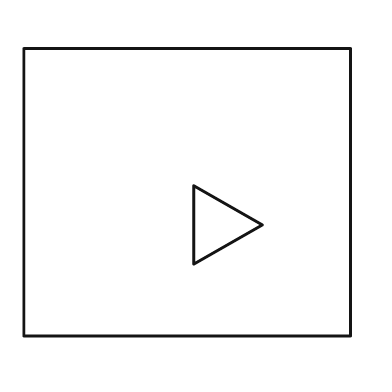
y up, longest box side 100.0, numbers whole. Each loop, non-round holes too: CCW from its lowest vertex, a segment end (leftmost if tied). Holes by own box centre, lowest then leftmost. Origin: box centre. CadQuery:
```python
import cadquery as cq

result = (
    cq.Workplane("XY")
    .moveTo(-50.0, -44.0)
    .lineTo(50.0, -44.0)
    .lineTo(50.0, 44.0)
    .lineTo(-50.0, 44.0)
    .close()
    .moveTo(2.0, -22.0)
    .lineTo(23.0, -10.0)
    .lineTo(2.0, 2.0)
    .close()
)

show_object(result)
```